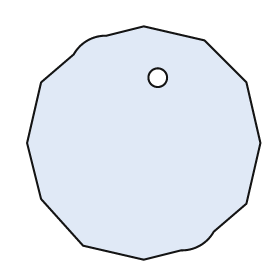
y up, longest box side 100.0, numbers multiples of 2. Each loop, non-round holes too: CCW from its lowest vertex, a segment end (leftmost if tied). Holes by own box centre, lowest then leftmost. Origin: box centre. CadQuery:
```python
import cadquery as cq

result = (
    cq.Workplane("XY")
    .moveTo(0.0, -50.0)
    .lineTo(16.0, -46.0)
    .threePointArc((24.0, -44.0), (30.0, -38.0))
    .lineTo(44.0, -26.0)
    .lineTo(50.0, 0.0)
    .lineTo(44.0, 26.0)
    .lineTo(26.0, 44.0)
    .lineTo(0.0, 50.0)
    .lineTo(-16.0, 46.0)
    .threePointArc((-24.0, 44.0), (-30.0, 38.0))
    .lineTo(-44.0, 26.0)
    .lineTo(-50.0, 0.0)
    .lineTo(-44.0, -24.0)
    .lineTo(-26.0, -44.0)
    .close()
    .moveTo(6.0, 28.0)
    .circle(4.0)
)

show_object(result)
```